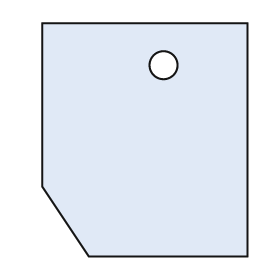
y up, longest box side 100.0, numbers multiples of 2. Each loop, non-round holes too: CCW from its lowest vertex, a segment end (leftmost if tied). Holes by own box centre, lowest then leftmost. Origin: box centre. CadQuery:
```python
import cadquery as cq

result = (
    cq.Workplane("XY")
    .moveTo(-24.0, -50.0)
    .lineTo(44.0, -50.0)
    .lineTo(44.0, 50.0)
    .lineTo(-44.0, 50.0)
    .lineTo(-44.0, -20.0)
    .close()
    .moveTo(8.0, 32.0)
    .circle(6.0)
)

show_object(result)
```